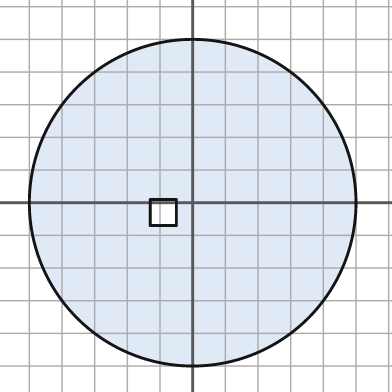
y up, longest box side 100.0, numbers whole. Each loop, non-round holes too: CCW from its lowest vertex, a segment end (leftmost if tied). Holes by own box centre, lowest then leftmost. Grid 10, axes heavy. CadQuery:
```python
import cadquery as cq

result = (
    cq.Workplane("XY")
    .moveTo(0.0, 0.0)
    .circle(50.0)
    .moveTo(-13.0, -7.0)
    .lineTo(-5.0, -7.0)
    .lineTo(-5.0, 1.0)
    .lineTo(-13.0, 1.0)
    .close()
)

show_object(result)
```